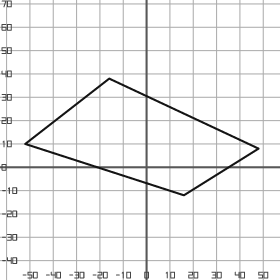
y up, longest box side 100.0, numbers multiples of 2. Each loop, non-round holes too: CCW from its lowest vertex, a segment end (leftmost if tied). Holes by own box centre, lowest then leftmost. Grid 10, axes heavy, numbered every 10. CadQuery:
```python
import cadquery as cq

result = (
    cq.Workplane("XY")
    .moveTo(16.0, -12.0)
    .lineTo(48.0, 8.0)
    .lineTo(-16.0, 38.0)
    .lineTo(-52.0, 10.0)
    .close()
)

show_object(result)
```